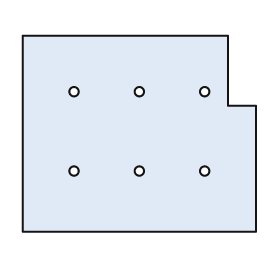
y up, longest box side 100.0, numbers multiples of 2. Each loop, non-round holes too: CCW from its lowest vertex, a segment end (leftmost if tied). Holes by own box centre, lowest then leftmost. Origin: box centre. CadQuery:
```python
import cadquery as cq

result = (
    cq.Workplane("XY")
    .moveTo(-50.0, -42.0)
    .lineTo(50.0, -42.0)
    .lineTo(50.0, 12.0)
    .lineTo(38.0, 12.0)
    .lineTo(38.0, 42.0)
    .lineTo(-50.0, 42.0)
    .close()
    .moveTo(-28.0, -16.0)
    .circle(2.0)
    .moveTo(0.0, -16.0)
    .circle(2.0)
    .moveTo(28.0, -16.0)
    .circle(2.0)
    .moveTo(-28.0, 18.0)
    .circle(2.0)
    .moveTo(0.0, 18.0)
    .circle(2.0)
    .moveTo(28.0, 18.0)
    .circle(2.0)
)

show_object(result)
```